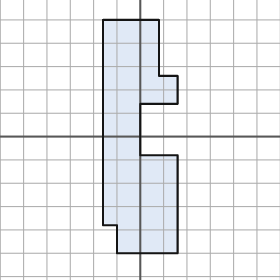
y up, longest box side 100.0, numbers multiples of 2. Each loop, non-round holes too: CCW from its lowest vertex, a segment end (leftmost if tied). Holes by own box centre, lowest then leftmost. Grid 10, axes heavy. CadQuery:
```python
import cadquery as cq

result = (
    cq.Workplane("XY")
    .moveTo(-10.0, -50.0)
    .lineTo(16.0, -50.0)
    .lineTo(16.0, -8.0)
    .lineTo(0.0, -8.0)
    .lineTo(0.0, 14.0)
    .lineTo(16.0, 14.0)
    .lineTo(16.0, 26.0)
    .lineTo(8.0, 26.0)
    .lineTo(8.0, 50.0)
    .lineTo(-16.0, 50.0)
    .lineTo(-16.0, -38.0)
    .lineTo(-10.0, -38.0)
    .close()
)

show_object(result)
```